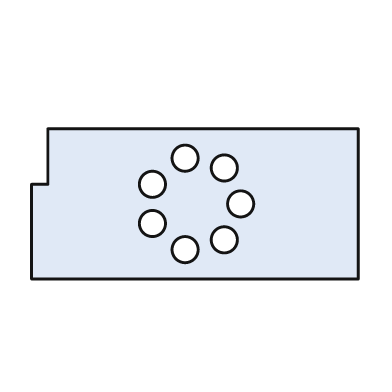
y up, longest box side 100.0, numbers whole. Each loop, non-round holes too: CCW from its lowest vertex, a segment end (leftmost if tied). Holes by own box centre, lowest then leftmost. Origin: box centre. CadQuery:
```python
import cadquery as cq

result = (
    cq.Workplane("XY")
    .moveTo(-50.0, -23.0)
    .lineTo(50.0, -23.0)
    .lineTo(50.0, 23.0)
    .lineTo(-45.0, 23.0)
    .lineTo(-45.0, 6.0)
    .lineTo(-50.0, 6.0)
    .close()
    .moveTo(-3.0, -14.0)
    .circle(4.0)
    .moveTo(9.0, -11.0)
    .circle(4.0)
    .moveTo(-13.0, -6.0)
    .circle(4.0)
    .moveTo(14.0, 0.0)
    .circle(4.0)
    .moveTo(-13.0, 6.0)
    .circle(4.0)
    .moveTo(9.0, 11.0)
    .circle(4.0)
    .moveTo(-3.0, 14.0)
    .circle(4.0)
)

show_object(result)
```